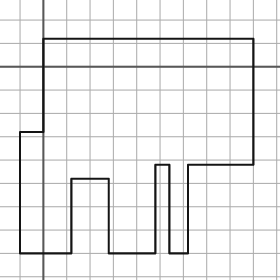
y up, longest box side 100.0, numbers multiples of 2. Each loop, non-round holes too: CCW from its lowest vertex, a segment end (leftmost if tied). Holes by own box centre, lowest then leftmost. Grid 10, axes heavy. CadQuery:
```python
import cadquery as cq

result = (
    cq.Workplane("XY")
    .moveTo(-10.0, -80.0)
    .lineTo(12.0, -80.0)
    .lineTo(12.0, -48.0)
    .lineTo(28.0, -48.0)
    .lineTo(28.0, -80.0)
    .lineTo(48.0, -80.0)
    .lineTo(48.0, -42.0)
    .lineTo(54.0, -42.0)
    .lineTo(54.0, -80.0)
    .lineTo(62.0, -80.0)
    .lineTo(62.0, -42.0)
    .lineTo(90.0, -42.0)
    .lineTo(90.0, 12.0)
    .lineTo(0.0, 12.0)
    .lineTo(0.0, -28.0)
    .lineTo(-10.0, -28.0)
    .close()
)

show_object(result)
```